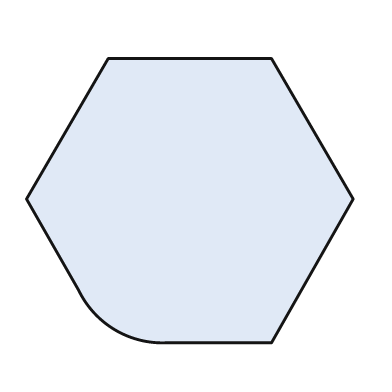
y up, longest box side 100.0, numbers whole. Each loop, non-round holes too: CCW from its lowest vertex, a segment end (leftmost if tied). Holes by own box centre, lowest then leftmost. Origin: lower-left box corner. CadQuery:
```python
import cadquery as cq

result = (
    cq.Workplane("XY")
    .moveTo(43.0, 0.0)
    .lineTo(75.0, 0.0)
    .lineTo(100.0, 44.0)
    .lineTo(75.0, 87.0)
    .lineTo(25.0, 87.0)
    .lineTo(0.0, 44.0)
    .lineTo(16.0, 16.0)
    .threePointArc((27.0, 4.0), (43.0, 0.0))
    .close()
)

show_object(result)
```